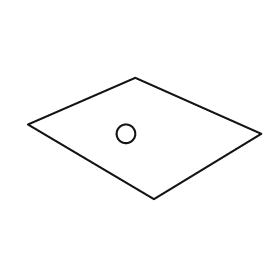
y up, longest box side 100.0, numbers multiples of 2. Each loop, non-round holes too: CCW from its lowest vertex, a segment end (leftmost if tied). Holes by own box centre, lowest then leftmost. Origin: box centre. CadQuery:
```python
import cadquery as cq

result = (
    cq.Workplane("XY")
    .moveTo(4.0, -26.0)
    .lineTo(50.0, 2.0)
    .lineTo(-4.0, 26.0)
    .lineTo(-50.0, 6.0)
    .close()
    .moveTo(-8.0, 2.0)
    .circle(4.0)
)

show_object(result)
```